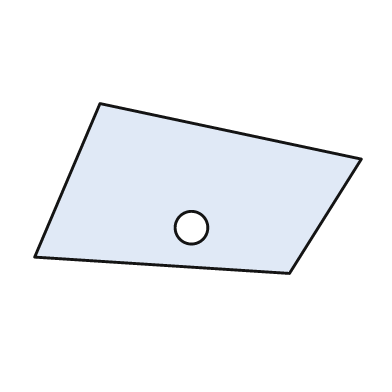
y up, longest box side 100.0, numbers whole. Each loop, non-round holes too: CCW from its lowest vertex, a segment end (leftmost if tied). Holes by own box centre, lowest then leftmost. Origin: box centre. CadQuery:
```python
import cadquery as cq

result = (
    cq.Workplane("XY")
    .moveTo(28.0, -26.0)
    .lineTo(50.0, 9.0)
    .lineTo(-30.0, 26.0)
    .lineTo(-50.0, -21.0)
    .close()
    .moveTo(-2.0, -12.0)
    .circle(5.0)
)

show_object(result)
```